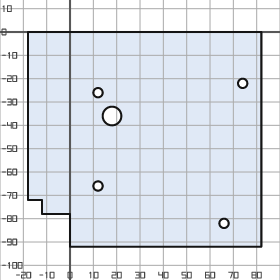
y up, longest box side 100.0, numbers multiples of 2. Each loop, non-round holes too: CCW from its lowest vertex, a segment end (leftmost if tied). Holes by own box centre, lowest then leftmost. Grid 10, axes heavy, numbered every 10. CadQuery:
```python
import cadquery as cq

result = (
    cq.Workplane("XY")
    .moveTo(0.0, -92.0)
    .lineTo(82.0, -92.0)
    .lineTo(82.0, 0.0)
    .lineTo(-18.0, 0.0)
    .lineTo(-18.0, -72.0)
    .lineTo(-12.0, -72.0)
    .lineTo(-12.0, -78.0)
    .lineTo(0.0, -78.0)
    .close()
    .moveTo(66.0, -82.0)
    .circle(2.0)
    .moveTo(12.0, -66.0)
    .circle(2.0)
    .moveTo(18.0, -36.0)
    .circle(4.0)
    .moveTo(12.0, -26.0)
    .circle(2.0)
    .moveTo(74.0, -22.0)
    .circle(2.0)
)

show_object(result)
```